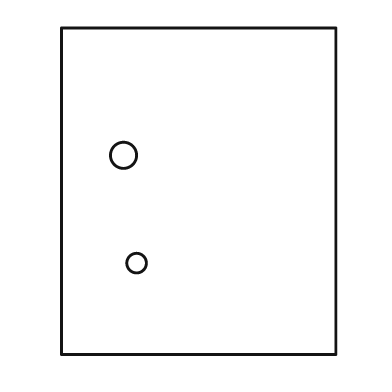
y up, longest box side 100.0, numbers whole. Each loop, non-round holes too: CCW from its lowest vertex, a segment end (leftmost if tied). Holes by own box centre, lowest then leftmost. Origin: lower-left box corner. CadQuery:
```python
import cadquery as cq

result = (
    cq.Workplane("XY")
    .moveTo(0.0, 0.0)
    .lineTo(84.0, 0.0)
    .lineTo(84.0, 100.0)
    .lineTo(0.0, 100.0)
    .close()
    .moveTo(23.0, 28.0)
    .circle(3.0)
    .moveTo(19.0, 61.0)
    .circle(4.0)
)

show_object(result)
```